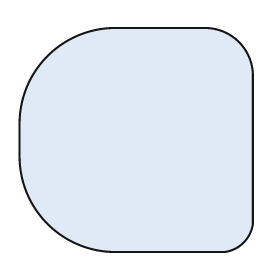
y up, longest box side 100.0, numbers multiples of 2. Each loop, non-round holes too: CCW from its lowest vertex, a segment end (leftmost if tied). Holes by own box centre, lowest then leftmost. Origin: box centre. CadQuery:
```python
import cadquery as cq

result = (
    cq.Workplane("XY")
    .moveTo(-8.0, -48.0)
    .lineTo(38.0, -48.0)
    .threePointArc((46.0, -44.0), (50.0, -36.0))
    .lineTo(50.0, 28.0)
    .threePointArc((44.0, 42.0), (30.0, 48.0))
    .lineTo(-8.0, 48.0)
    .threePointArc((-38.0, 36.0), (-50.0, 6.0))
    .lineTo(-50.0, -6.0)
    .threePointArc((-38.0, -36.0), (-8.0, -48.0))
    .close()
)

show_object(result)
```